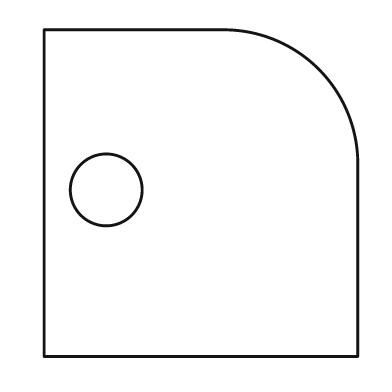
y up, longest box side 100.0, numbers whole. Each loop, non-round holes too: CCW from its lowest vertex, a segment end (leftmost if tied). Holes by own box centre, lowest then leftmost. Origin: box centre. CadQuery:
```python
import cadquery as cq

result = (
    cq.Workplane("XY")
    .moveTo(-48.0, -50.0)
    .lineTo(48.0, -50.0)
    .lineTo(48.0, 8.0)
    .threePointArc((36.0, 38.0), (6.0, 50.0))
    .lineTo(-48.0, 50.0)
    .close()
    .moveTo(-29.0, 1.0)
    .circle(11.0)
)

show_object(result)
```